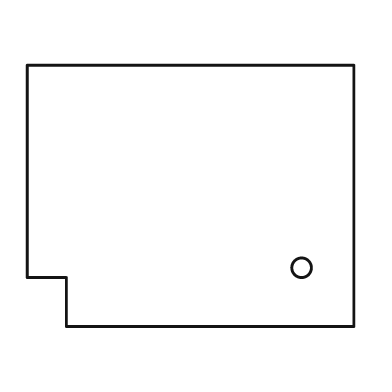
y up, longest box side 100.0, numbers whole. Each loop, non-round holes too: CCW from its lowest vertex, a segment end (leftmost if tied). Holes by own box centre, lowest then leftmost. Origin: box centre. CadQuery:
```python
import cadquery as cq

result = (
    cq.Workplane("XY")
    .moveTo(-38.0, -40.0)
    .lineTo(50.0, -40.0)
    .lineTo(50.0, 40.0)
    .lineTo(-50.0, 40.0)
    .lineTo(-50.0, -25.0)
    .lineTo(-38.0, -25.0)
    .close()
    .moveTo(34.0, -22.0)
    .circle(3.0)
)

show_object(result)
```